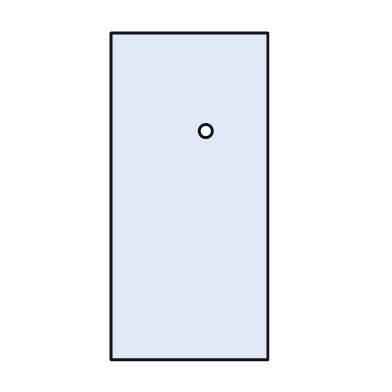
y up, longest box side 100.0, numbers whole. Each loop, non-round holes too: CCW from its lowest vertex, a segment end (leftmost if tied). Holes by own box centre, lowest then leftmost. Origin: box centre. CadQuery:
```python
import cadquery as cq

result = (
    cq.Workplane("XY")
    .moveTo(-24.0, -50.0)
    .lineTo(24.0, -50.0)
    .lineTo(24.0, 50.0)
    .lineTo(-24.0, 50.0)
    .close()
    .moveTo(5.0, 20.0)
    .circle(2.0)
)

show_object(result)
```